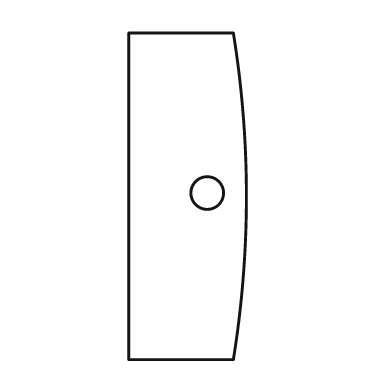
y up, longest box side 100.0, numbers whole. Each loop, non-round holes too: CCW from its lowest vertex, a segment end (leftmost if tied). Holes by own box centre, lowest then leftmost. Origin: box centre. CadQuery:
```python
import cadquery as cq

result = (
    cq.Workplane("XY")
    .moveTo(-18.0, -50.0)
    .lineTo(14.0, -50.0)
    .threePointArc((18.0, 0.0), (14.0, 50.0))
    .lineTo(-18.0, 50.0)
    .close()
    .moveTo(6.0, 1.0)
    .circle(5.0)
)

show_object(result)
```